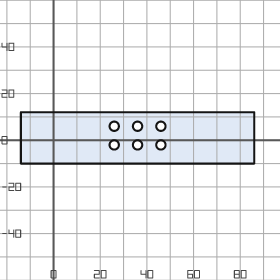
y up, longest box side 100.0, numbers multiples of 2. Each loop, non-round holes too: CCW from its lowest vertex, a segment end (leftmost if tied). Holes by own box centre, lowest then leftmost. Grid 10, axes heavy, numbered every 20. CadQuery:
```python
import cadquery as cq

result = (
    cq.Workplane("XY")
    .moveTo(-14.0, -10.0)
    .lineTo(86.0, -10.0)
    .lineTo(86.0, 12.0)
    .lineTo(-14.0, 12.0)
    .close()
    .moveTo(26.0, -2.0)
    .circle(2.0)
    .moveTo(36.0, -2.0)
    .circle(2.0)
    .moveTo(46.0, -2.0)
    .circle(2.0)
    .moveTo(26.0, 6.0)
    .circle(2.0)
    .moveTo(36.0, 6.0)
    .circle(2.0)
    .moveTo(46.0, 6.0)
    .circle(2.0)
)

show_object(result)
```